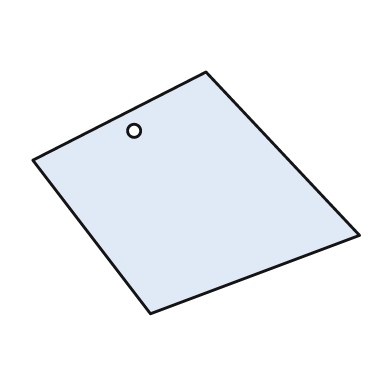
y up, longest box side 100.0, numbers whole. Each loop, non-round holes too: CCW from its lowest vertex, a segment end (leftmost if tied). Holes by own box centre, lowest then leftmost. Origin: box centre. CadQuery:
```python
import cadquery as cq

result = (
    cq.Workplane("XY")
    .moveTo(-14.0, -37.0)
    .lineTo(50.0, -13.0)
    .lineTo(3.0, 37.0)
    .lineTo(-50.0, 10.0)
    .close()
    .moveTo(-19.0, 19.0)
    .circle(2.0)
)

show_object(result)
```